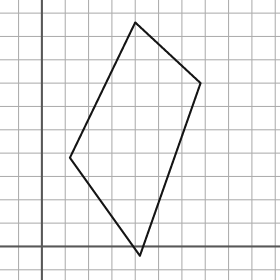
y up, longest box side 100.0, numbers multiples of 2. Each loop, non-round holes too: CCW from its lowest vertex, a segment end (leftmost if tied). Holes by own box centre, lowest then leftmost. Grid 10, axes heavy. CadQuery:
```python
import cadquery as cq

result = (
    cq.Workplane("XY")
    .moveTo(42.0, -4.0)
    .lineTo(68.0, 70.0)
    .lineTo(40.0, 96.0)
    .lineTo(12.0, 38.0)
    .close()
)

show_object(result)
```